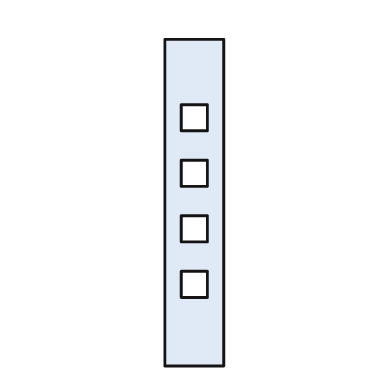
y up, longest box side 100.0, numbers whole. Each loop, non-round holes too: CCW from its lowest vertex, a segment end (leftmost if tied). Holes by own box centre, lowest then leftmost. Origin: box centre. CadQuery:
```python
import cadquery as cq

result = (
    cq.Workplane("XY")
    .moveTo(-9.0, -50.0)
    .lineTo(9.0, -50.0)
    .lineTo(9.0, 50.0)
    .lineTo(-9.0, 50.0)
    .close()
    .moveTo(-4.0, -29.0)
    .lineTo(4.0, -29.0)
    .lineTo(4.0, -21.0)
    .lineTo(-4.0, -21.0)
    .close()
    .moveTo(-4.0, -12.0)
    .lineTo(4.0, -12.0)
    .lineTo(4.0, -4.0)
    .lineTo(-4.0, -4.0)
    .close()
    .moveTo(-4.0, 5.0)
    .lineTo(4.0, 5.0)
    .lineTo(4.0, 13.0)
    .lineTo(-4.0, 13.0)
    .close()
    .moveTo(-4.0, 22.0)
    .lineTo(4.0, 22.0)
    .lineTo(4.0, 30.0)
    .lineTo(-4.0, 30.0)
    .close()
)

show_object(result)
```